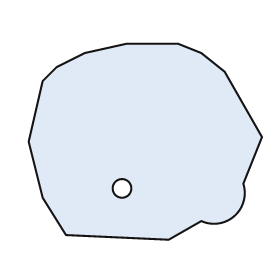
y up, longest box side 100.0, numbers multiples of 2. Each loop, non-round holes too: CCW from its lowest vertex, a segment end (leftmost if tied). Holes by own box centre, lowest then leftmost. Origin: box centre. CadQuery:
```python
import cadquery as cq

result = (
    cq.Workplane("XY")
    .moveTo(10.0, -42.0)
    .lineTo(24.0, -34.0)
    .threePointArc((38.0, -32.0), (42.0, -18.0))
    .lineTo(50.0, 2.0)
    .lineTo(34.0, 30.0)
    .lineTo(24.0, 38.0)
    .lineTo(14.0, 42.0)
    .lineTo(-8.0, 42.0)
    .lineTo(-26.0, 38.0)
    .lineTo(-38.0, 32.0)
    .lineTo(-44.0, 26.0)
    .lineTo(-50.0, 0.0)
    .lineTo(-44.0, -24.0)
    .lineTo(-34.0, -40.0)
    .close()
    .moveTo(-10.0, -20.0)
    .circle(4.0)
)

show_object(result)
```